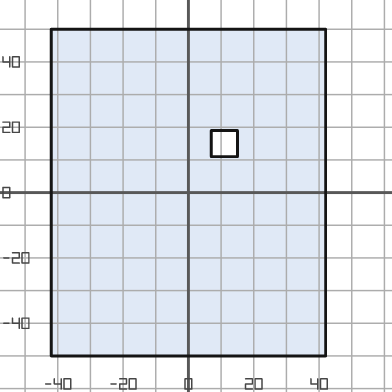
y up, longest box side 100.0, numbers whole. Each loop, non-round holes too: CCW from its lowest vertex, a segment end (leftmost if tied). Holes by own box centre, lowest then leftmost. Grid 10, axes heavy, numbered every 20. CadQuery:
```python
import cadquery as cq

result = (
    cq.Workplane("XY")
    .moveTo(-42.0, -50.0)
    .lineTo(42.0, -50.0)
    .lineTo(42.0, 50.0)
    .lineTo(-42.0, 50.0)
    .close()
    .moveTo(7.0, 11.0)
    .lineTo(15.0, 11.0)
    .lineTo(15.0, 19.0)
    .lineTo(7.0, 19.0)
    .close()
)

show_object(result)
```